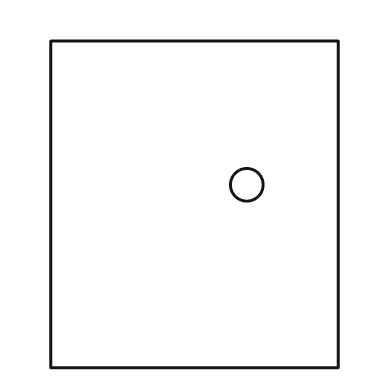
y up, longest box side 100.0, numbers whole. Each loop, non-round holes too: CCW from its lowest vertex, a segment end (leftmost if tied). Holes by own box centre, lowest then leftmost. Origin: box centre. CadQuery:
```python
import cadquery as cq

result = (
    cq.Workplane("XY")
    .moveTo(-44.0, -50.0)
    .lineTo(44.0, -50.0)
    .lineTo(44.0, 50.0)
    .lineTo(-44.0, 50.0)
    .close()
    .moveTo(16.0, 6.0)
    .circle(5.0)
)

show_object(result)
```